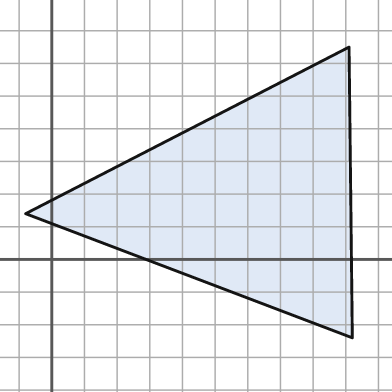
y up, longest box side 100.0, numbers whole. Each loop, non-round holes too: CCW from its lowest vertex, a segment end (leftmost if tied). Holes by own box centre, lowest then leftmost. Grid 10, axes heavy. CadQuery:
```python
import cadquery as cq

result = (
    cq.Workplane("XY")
    .moveTo(92.0, -24.0)
    .lineTo(91.0, 65.0)
    .lineTo(-8.0, 14.0)
    .close()
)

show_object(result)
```